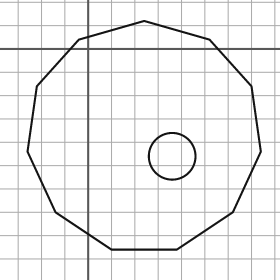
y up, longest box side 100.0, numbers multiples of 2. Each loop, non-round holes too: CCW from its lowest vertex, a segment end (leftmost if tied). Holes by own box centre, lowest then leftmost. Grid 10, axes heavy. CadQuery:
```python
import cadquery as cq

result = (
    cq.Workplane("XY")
    .moveTo(10.0, -86.0)
    .lineTo(38.0, -86.0)
    .lineTo(62.0, -70.0)
    .lineTo(74.0, -44.0)
    .lineTo(70.0, -16.0)
    .lineTo(52.0, 4.0)
    .lineTo(24.0, 12.0)
    .lineTo(-4.0, 4.0)
    .lineTo(-22.0, -16.0)
    .lineTo(-26.0, -44.0)
    .lineTo(-14.0, -70.0)
    .close()
    .moveTo(36.0, -46.0)
    .circle(10.0)
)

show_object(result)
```